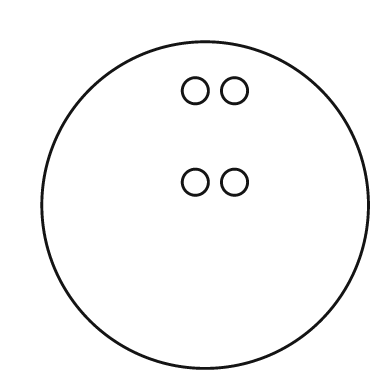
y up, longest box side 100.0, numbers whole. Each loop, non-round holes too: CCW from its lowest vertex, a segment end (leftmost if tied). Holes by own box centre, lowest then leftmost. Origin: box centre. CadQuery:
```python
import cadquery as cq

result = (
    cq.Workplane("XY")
    .moveTo(0.0, 0.0)
    .circle(50.0)
    .moveTo(-3.0, 7.0)
    .circle(4.0)
    .moveTo(9.0, 7.0)
    .circle(4.0)
    .moveTo(-3.0, 35.0)
    .circle(4.0)
    .moveTo(9.0, 35.0)
    .circle(4.0)
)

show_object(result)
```